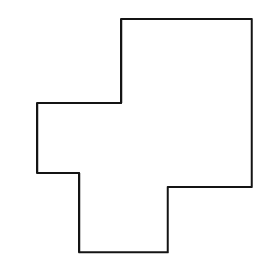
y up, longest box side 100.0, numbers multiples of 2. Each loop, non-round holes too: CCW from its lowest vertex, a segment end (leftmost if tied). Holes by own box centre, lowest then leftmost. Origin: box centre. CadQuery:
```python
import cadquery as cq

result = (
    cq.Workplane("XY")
    .moveTo(-28.0, -50.0)
    .lineTo(10.0, -50.0)
    .lineTo(10.0, -22.0)
    .lineTo(46.0, -22.0)
    .lineTo(46.0, 50.0)
    .lineTo(-10.0, 50.0)
    .lineTo(-10.0, 14.0)
    .lineTo(-46.0, 14.0)
    .lineTo(-46.0, -16.0)
    .lineTo(-28.0, -16.0)
    .close()
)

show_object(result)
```